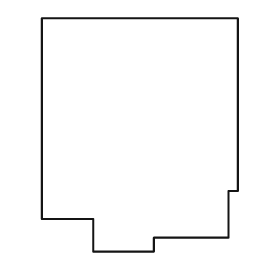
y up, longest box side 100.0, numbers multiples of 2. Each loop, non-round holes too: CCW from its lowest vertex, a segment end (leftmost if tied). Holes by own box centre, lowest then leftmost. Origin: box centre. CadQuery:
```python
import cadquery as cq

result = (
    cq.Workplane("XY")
    .moveTo(-20.0, -50.0)
    .lineTo(6.0, -50.0)
    .lineTo(6.0, -44.0)
    .lineTo(38.0, -44.0)
    .lineTo(38.0, -24.0)
    .lineTo(42.0, -24.0)
    .lineTo(42.0, 50.0)
    .lineTo(-42.0, 50.0)
    .lineTo(-42.0, -36.0)
    .lineTo(-20.0, -36.0)
    .close()
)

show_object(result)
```